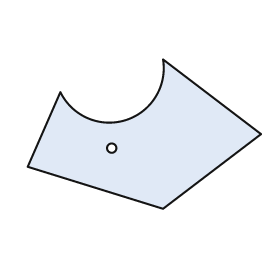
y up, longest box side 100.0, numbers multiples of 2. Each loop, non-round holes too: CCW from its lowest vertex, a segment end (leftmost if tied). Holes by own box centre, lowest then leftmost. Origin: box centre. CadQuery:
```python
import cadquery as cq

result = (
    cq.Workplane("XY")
    .moveTo(8.0, -32.0)
    .lineTo(50.0, 0.0)
    .lineTo(8.0, 32.0)
    .threePointArc((-8.0, 6.0), (-36.0, 18.0))
    .lineTo(-50.0, -14.0)
    .close()
    .moveTo(-14.0, -6.0)
    .circle(2.0)
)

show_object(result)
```